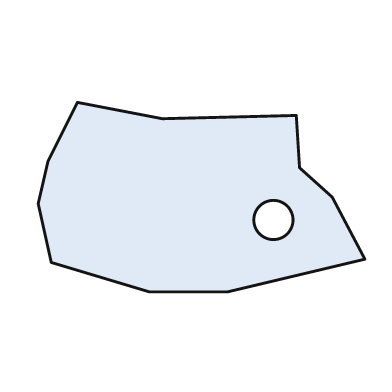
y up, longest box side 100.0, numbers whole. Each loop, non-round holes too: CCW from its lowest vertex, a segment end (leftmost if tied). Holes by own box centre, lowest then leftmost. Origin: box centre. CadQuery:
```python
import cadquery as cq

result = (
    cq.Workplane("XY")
    .moveTo(-16.0, -29.0)
    .lineTo(8.0, -29.0)
    .lineTo(50.0, -19.0)
    .lineTo(40.0, 0.0)
    .lineTo(30.0, 9.0)
    .lineTo(29.0, 25.0)
    .lineTo(-12.0, 24.0)
    .lineTo(-38.0, 29.0)
    .lineTo(-47.0, 11.0)
    .lineTo(-50.0, -2.0)
    .lineTo(-46.0, -20.0)
    .close()
    .moveTo(22.0, -7.0)
    .circle(6.0)
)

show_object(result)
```